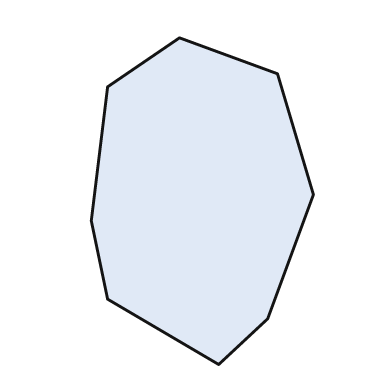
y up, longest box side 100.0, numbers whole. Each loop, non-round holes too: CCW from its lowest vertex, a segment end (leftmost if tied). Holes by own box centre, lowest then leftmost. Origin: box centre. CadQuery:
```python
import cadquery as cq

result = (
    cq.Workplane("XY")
    .moveTo(5.0, -50.0)
    .lineTo(20.0, -36.0)
    .lineTo(34.0, 2.0)
    .lineTo(23.0, 39.0)
    .lineTo(-7.0, 50.0)
    .lineTo(-29.0, 35.0)
    .lineTo(-34.0, -6.0)
    .lineTo(-29.0, -30.0)
    .close()
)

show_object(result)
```